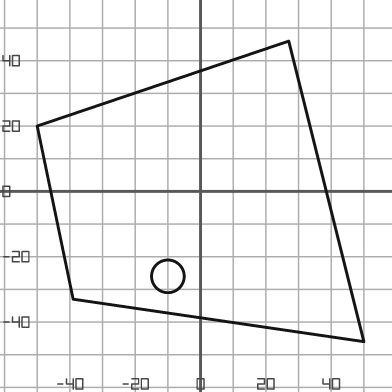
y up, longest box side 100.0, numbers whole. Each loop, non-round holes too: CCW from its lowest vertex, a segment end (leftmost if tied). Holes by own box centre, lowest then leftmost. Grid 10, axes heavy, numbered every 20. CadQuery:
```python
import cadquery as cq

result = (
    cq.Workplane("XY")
    .moveTo(50.0, -46.0)
    .lineTo(27.0, 46.0)
    .lineTo(-50.0, 20.0)
    .lineTo(-39.0, -33.0)
    .close()
    .moveTo(-10.0, -26.0)
    .circle(5.0)
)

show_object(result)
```